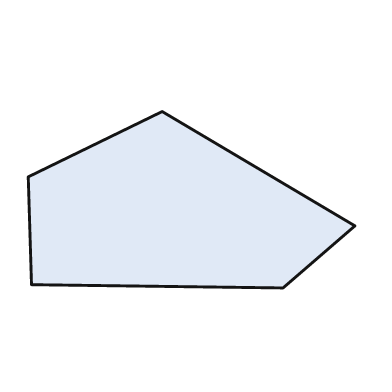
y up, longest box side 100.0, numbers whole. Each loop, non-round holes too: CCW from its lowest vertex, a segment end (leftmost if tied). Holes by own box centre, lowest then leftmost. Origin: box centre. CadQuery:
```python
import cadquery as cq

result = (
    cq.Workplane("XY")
    .moveTo(28.0, -27.0)
    .lineTo(50.0, -8.0)
    .lineTo(-9.0, 27.0)
    .lineTo(-50.0, 7.0)
    .lineTo(-49.0, -26.0)
    .close()
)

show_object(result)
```